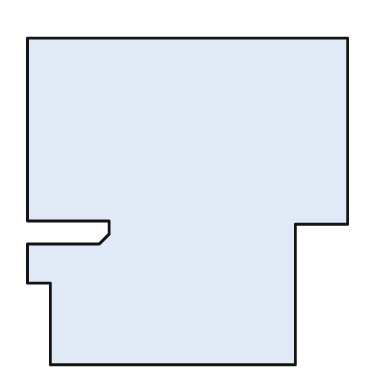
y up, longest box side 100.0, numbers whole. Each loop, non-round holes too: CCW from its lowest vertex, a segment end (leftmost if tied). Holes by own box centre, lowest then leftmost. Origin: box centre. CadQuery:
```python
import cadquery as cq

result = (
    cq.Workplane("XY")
    .moveTo(-42.0, -50.0)
    .lineTo(33.0, -50.0)
    .lineTo(33.0, -7.0)
    .lineTo(49.0, -7.0)
    .lineTo(49.0, 50.0)
    .lineTo(-49.0, 50.0)
    .lineTo(-49.0, -6.0)
    .lineTo(-24.0, -6.0)
    .lineTo(-24.0, -10.0)
    .lineTo(-27.0, -13.0)
    .lineTo(-49.0, -13.0)
    .lineTo(-49.0, -25.0)
    .lineTo(-42.0, -25.0)
    .close()
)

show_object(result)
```